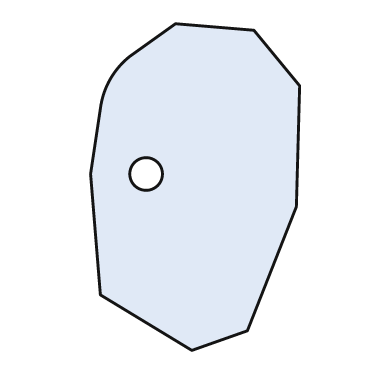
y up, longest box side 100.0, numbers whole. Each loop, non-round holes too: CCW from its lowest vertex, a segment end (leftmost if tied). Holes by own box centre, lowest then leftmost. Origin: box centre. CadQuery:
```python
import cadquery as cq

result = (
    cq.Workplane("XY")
    .moveTo(-1.0, -50.0)
    .lineTo(16.0, -44.0)
    .lineTo(31.0, -6.0)
    .lineTo(32.0, 31.0)
    .lineTo(18.0, 48.0)
    .lineTo(-6.0, 50.0)
    .lineTo(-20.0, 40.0)
    .threePointArc((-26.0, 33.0), (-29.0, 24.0))
    .lineTo(-32.0, 4.0)
    .lineTo(-29.0, -33.0)
    .close()
    .moveTo(-15.0, 4.0)
    .circle(5.0)
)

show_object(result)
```